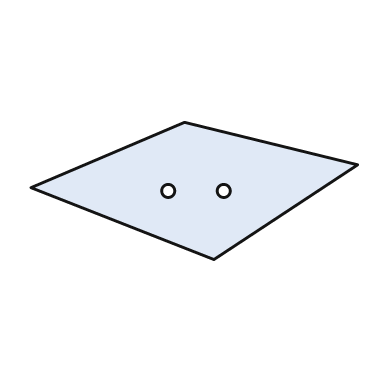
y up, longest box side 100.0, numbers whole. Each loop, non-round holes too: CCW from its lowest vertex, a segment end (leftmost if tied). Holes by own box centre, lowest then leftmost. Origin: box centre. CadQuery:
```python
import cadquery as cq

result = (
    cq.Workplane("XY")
    .moveTo(6.0, -21.0)
    .lineTo(50.0, 8.0)
    .lineTo(-3.0, 21.0)
    .lineTo(-50.0, 1.0)
    .close()
    .moveTo(-8.0, 0.0)
    .circle(2.0)
    .moveTo(9.0, 0.0)
    .circle(2.0)
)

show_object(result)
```